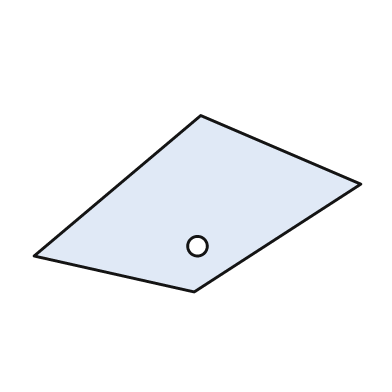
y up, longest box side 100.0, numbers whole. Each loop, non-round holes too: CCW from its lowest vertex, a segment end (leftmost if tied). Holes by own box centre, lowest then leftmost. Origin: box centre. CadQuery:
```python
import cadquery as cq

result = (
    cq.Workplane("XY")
    .moveTo(-1.0, -27.0)
    .lineTo(50.0, 6.0)
    .lineTo(1.0, 27.0)
    .lineTo(-50.0, -16.0)
    .close()
    .moveTo(0.0, -13.0)
    .circle(3.0)
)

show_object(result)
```